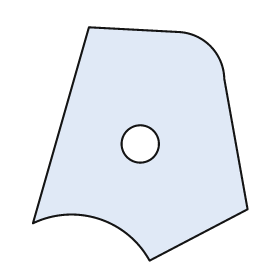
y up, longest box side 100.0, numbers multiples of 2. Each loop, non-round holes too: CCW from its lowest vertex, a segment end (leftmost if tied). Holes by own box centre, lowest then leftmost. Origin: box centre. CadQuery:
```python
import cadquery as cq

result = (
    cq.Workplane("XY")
    .moveTo(4.0, -50.0)
    .lineTo(46.0, -28.0)
    .lineTo(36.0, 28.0)
    .threePointArc((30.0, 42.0), (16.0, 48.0))
    .lineTo(-22.0, 50.0)
    .lineTo(-46.0, -34.0)
    .threePointArc((-18.0, -32.0), (4.0, -50.0))
    .close()
    .moveTo(0.0, 0.0)
    .circle(8.0)
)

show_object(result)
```